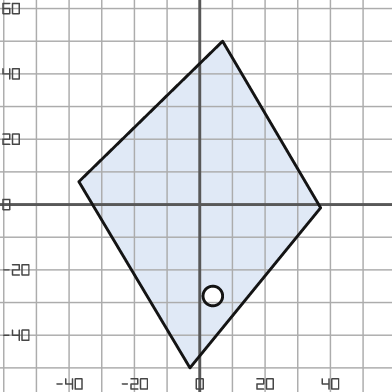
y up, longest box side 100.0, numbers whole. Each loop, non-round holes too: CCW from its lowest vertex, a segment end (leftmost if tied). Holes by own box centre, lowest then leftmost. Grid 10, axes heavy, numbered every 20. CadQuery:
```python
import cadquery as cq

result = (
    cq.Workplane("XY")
    .moveTo(-3.0, -50.0)
    .lineTo(37.0, -1.0)
    .lineTo(7.0, 50.0)
    .lineTo(-37.0, 7.0)
    .close()
    .moveTo(4.0, -28.0)
    .circle(3.0)
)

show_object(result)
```